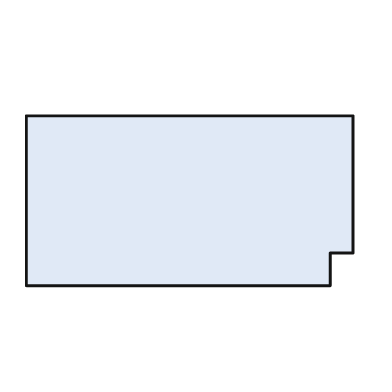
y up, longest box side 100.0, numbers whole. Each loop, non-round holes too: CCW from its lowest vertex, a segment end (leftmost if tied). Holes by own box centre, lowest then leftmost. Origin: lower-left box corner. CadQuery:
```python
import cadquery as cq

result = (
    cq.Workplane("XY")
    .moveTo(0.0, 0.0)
    .lineTo(93.0, 0.0)
    .lineTo(93.0, 10.0)
    .lineTo(100.0, 10.0)
    .lineTo(100.0, 52.0)
    .lineTo(0.0, 52.0)
    .close()
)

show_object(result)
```